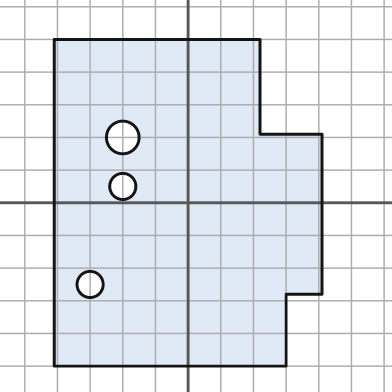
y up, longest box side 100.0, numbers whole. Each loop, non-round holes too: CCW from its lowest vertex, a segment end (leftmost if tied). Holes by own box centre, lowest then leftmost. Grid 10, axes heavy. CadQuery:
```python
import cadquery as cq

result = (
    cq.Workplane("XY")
    .moveTo(-41.0, -50.0)
    .lineTo(30.0, -50.0)
    .lineTo(30.0, -28.0)
    .lineTo(41.0, -28.0)
    .lineTo(41.0, 21.0)
    .lineTo(22.0, 21.0)
    .lineTo(22.0, 50.0)
    .lineTo(-41.0, 50.0)
    .close()
    .moveTo(-30.0, -25.0)
    .circle(4.0)
    .moveTo(-20.0, 5.0)
    .circle(4.0)
    .moveTo(-20.0, 20.0)
    .circle(5.0)
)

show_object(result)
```